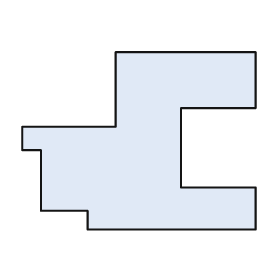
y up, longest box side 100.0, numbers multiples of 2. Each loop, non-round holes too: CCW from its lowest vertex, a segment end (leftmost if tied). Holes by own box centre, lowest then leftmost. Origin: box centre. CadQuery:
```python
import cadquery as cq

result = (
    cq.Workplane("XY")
    .moveTo(-22.0, -38.0)
    .lineTo(50.0, -38.0)
    .lineTo(50.0, -20.0)
    .lineTo(18.0, -20.0)
    .lineTo(18.0, 14.0)
    .lineTo(50.0, 14.0)
    .lineTo(50.0, 38.0)
    .lineTo(-10.0, 38.0)
    .lineTo(-10.0, 6.0)
    .lineTo(-50.0, 6.0)
    .lineTo(-50.0, -4.0)
    .lineTo(-42.0, -4.0)
    .lineTo(-42.0, -30.0)
    .lineTo(-22.0, -30.0)
    .close()
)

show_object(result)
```